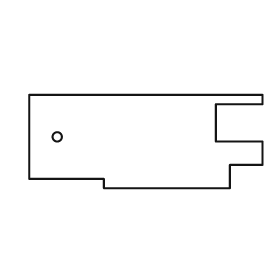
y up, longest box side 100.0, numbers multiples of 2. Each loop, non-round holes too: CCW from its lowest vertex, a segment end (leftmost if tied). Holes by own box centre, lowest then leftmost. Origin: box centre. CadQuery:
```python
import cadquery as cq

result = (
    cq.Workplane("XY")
    .moveTo(-18.0, -20.0)
    .lineTo(36.0, -20.0)
    .lineTo(36.0, -10.0)
    .lineTo(50.0, -10.0)
    .lineTo(50.0, 0.0)
    .lineTo(30.0, 0.0)
    .lineTo(30.0, 16.0)
    .lineTo(50.0, 16.0)
    .lineTo(50.0, 20.0)
    .lineTo(-50.0, 20.0)
    .lineTo(-50.0, -16.0)
    .lineTo(-18.0, -16.0)
    .close()
    .moveTo(-38.0, 2.0)
    .circle(2.0)
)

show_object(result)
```